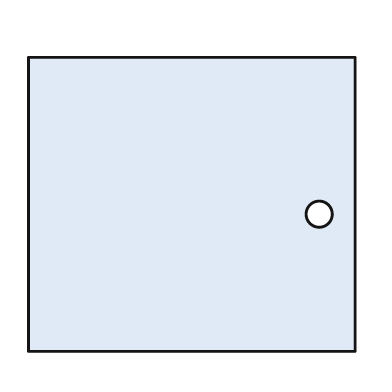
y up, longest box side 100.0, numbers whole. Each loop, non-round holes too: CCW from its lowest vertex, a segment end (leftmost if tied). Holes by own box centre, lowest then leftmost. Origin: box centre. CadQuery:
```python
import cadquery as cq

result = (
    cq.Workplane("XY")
    .moveTo(-50.0, -45.0)
    .lineTo(50.0, -45.0)
    .lineTo(50.0, 45.0)
    .lineTo(-50.0, 45.0)
    .close()
    .moveTo(39.0, -3.0)
    .circle(4.0)
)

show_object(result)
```